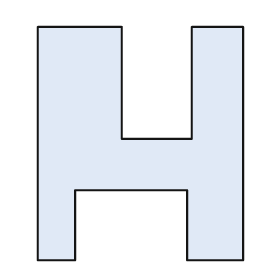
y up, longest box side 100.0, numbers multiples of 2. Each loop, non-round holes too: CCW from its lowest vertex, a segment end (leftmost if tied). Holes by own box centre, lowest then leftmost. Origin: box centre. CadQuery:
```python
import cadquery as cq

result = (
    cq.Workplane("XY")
    .moveTo(-44.0, -50.0)
    .lineTo(-28.0, -50.0)
    .lineTo(-28.0, -20.0)
    .lineTo(20.0, -20.0)
    .lineTo(20.0, -50.0)
    .lineTo(44.0, -50.0)
    .lineTo(44.0, 50.0)
    .lineTo(22.0, 50.0)
    .lineTo(22.0, 2.0)
    .lineTo(-8.0, 2.0)
    .lineTo(-8.0, 50.0)
    .lineTo(-44.0, 50.0)
    .close()
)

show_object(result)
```